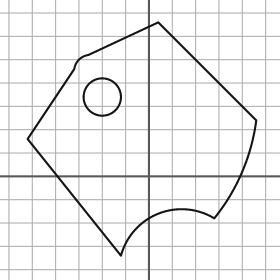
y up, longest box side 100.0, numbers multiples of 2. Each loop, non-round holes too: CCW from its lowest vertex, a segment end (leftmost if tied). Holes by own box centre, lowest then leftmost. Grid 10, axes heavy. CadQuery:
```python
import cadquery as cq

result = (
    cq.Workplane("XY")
    .moveTo(-12.0, -34.0)
    .threePointArc((4.0, -16.0), (28.0, -18.0))
    .threePointArc((40.0, 2.0), (46.0, 24.0))
    .lineTo(4.0, 66.0)
    .lineTo(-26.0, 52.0)
    .threePointArc((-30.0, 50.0), (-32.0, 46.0))
    .lineTo(-52.0, 16.0)
    .close()
    .moveTo(-20.0, 34.0)
    .circle(8.0)
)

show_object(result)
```